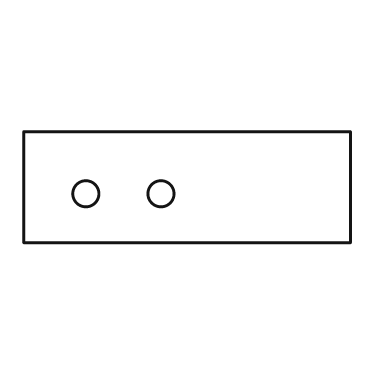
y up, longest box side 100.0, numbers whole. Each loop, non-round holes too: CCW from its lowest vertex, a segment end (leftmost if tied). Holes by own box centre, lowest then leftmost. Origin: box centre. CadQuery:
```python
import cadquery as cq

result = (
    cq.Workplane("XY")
    .moveTo(-50.0, -17.0)
    .lineTo(50.0, -17.0)
    .lineTo(50.0, 17.0)
    .lineTo(-50.0, 17.0)
    .close()
    .moveTo(-31.0, -2.0)
    .circle(4.0)
    .moveTo(-8.0, -2.0)
    .circle(4.0)
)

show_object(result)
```